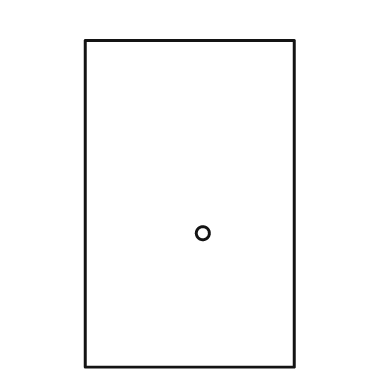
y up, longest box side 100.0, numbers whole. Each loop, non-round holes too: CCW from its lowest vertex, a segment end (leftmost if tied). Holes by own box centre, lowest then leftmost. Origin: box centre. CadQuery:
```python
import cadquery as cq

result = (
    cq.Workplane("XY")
    .moveTo(-32.0, -50.0)
    .lineTo(32.0, -50.0)
    .lineTo(32.0, 50.0)
    .lineTo(-32.0, 50.0)
    .close()
    .moveTo(4.0, -9.0)
    .circle(2.0)
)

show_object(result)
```